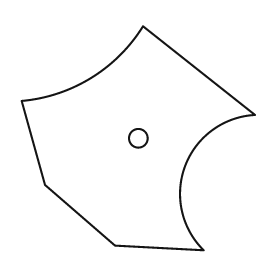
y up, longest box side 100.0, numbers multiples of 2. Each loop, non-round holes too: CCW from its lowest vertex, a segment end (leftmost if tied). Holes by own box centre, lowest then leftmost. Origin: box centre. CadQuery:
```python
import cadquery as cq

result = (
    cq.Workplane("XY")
    .moveTo(28.0, -48.0)
    .threePointArc((20.0, -12.0), (50.0, 10.0))
    .lineTo(2.0, 48.0)
    .threePointArc((-20.0, 26.0), (-50.0, 16.0))
    .lineTo(-40.0, -20.0)
    .lineTo(-10.0, -46.0)
    .close()
    .moveTo(0.0, 0.0)
    .circle(4.0)
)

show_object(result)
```